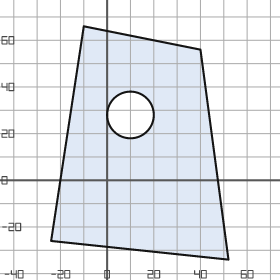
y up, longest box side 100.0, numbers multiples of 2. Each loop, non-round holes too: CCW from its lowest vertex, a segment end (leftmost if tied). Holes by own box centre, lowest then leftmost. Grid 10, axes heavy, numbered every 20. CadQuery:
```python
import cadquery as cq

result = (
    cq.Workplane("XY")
    .moveTo(52.0, -34.0)
    .lineTo(40.0, 56.0)
    .lineTo(-10.0, 66.0)
    .lineTo(-24.0, -26.0)
    .close()
    .moveTo(10.0, 28.0)
    .circle(10.0)
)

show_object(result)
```